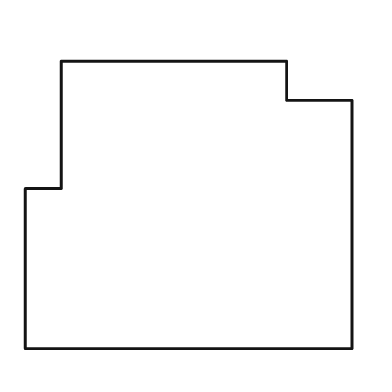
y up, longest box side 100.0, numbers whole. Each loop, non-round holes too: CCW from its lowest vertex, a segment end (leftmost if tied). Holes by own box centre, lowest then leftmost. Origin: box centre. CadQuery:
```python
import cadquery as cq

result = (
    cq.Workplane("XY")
    .moveTo(-50.0, -44.0)
    .lineTo(50.0, -44.0)
    .lineTo(50.0, 32.0)
    .lineTo(30.0, 32.0)
    .lineTo(30.0, 44.0)
    .lineTo(-39.0, 44.0)
    .lineTo(-39.0, 5.0)
    .lineTo(-50.0, 5.0)
    .close()
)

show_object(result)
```